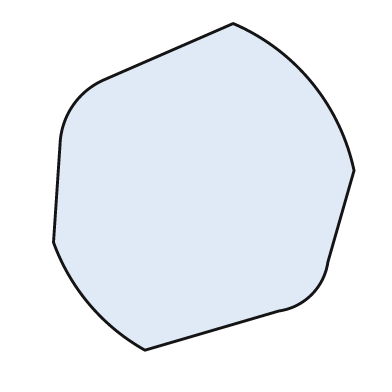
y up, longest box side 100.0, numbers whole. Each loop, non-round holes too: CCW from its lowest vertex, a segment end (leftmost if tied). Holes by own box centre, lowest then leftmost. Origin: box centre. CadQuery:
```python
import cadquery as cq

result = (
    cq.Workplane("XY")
    .moveTo(-18.0, -50.0)
    .lineTo(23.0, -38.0)
    .threePointArc((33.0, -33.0), (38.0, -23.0))
    .lineTo(46.0, 5.0)
    .threePointArc((33.0, 32.0), (9.0, 50.0))
    .lineTo(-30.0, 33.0)
    .threePointArc((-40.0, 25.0), (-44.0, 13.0))
    .lineTo(-46.0, -17.0)
    .threePointArc((-35.0, -36.0), (-18.0, -50.0))
    .close()
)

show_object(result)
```